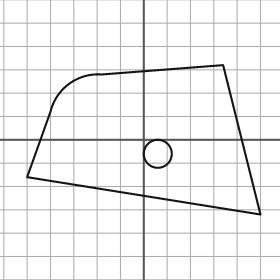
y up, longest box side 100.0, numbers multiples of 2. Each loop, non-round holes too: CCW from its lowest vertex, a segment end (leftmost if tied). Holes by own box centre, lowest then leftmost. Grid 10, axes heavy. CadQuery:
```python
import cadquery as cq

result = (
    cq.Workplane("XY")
    .moveTo(50.0, -32.0)
    .lineTo(34.0, 32.0)
    .lineTo(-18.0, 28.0)
    .threePointArc((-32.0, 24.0), (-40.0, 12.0))
    .lineTo(-50.0, -16.0)
    .close()
    .moveTo(6.0, -6.0)
    .circle(6.0)
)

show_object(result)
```